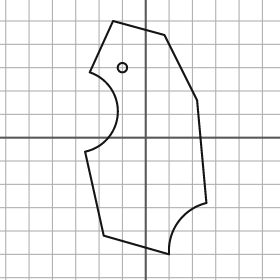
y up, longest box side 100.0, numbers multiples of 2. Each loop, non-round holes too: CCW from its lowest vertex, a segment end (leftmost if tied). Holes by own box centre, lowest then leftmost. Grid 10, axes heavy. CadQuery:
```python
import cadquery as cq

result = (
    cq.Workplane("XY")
    .moveTo(10.0, -50.0)
    .threePointArc((14.0, -36.0), (26.0, -28.0))
    .lineTo(22.0, 16.0)
    .lineTo(8.0, 44.0)
    .lineTo(-14.0, 50.0)
    .lineTo(-24.0, 28.0)
    .threePointArc((-12.0, 10.0), (-26.0, -6.0))
    .lineTo(-18.0, -42.0)
    .close()
    .moveTo(-10.0, 30.0)
    .circle(2.0)
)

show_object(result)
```